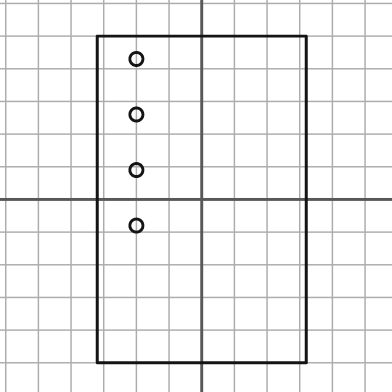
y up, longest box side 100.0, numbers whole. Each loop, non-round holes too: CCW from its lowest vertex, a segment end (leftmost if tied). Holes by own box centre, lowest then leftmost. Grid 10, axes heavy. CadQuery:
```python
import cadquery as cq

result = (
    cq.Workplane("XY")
    .moveTo(-32.0, -50.0)
    .lineTo(32.0, -50.0)
    .lineTo(32.0, 50.0)
    .lineTo(-32.0, 50.0)
    .close()
    .moveTo(-20.0, -8.0)
    .circle(2.0)
    .moveTo(-20.0, 9.0)
    .circle(2.0)
    .moveTo(-20.0, 26.0)
    .circle(2.0)
    .moveTo(-20.0, 43.0)
    .circle(2.0)
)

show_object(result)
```